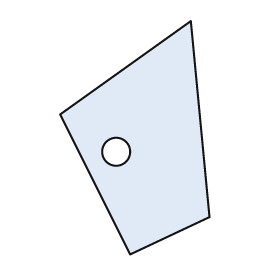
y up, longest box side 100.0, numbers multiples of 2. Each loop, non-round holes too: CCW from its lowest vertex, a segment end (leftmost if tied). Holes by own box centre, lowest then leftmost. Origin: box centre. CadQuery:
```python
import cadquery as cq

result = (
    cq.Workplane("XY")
    .moveTo(-2.0, -50.0)
    .lineTo(32.0, -34.0)
    .lineTo(24.0, 50.0)
    .lineTo(-32.0, 10.0)
    .close()
    .moveTo(-8.0, -6.0)
    .circle(6.0)
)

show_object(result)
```